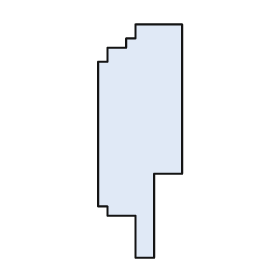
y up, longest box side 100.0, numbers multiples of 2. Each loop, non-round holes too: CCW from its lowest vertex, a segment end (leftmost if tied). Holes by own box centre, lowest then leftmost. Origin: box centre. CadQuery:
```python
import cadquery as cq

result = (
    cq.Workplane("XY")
    .moveTo(-2.0, -50.0)
    .lineTo(6.0, -50.0)
    .lineTo(6.0, -14.0)
    .lineTo(18.0, -14.0)
    .lineTo(18.0, 50.0)
    .lineTo(-2.0, 50.0)
    .lineTo(-2.0, 44.0)
    .lineTo(-6.0, 44.0)
    .lineTo(-6.0, 40.0)
    .lineTo(-14.0, 40.0)
    .lineTo(-14.0, 34.0)
    .lineTo(-18.0, 34.0)
    .lineTo(-18.0, -28.0)
    .lineTo(-14.0, -28.0)
    .lineTo(-14.0, -32.0)
    .lineTo(-2.0, -32.0)
    .close()
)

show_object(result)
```